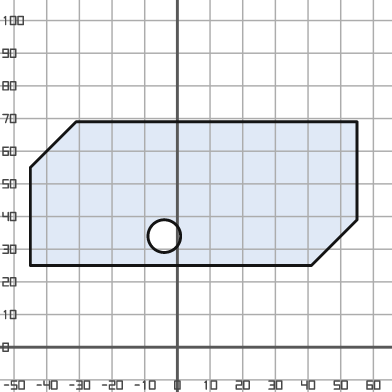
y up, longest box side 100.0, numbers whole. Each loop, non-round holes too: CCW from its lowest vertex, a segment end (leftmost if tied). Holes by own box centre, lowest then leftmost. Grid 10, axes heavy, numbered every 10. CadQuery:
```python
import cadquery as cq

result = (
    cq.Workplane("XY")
    .moveTo(-45.0, 25.0)
    .lineTo(41.0, 25.0)
    .lineTo(55.0, 39.0)
    .lineTo(55.0, 69.0)
    .lineTo(-31.0, 69.0)
    .lineTo(-45.0, 55.0)
    .close()
    .moveTo(-4.0, 34.0)
    .circle(5.0)
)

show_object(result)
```